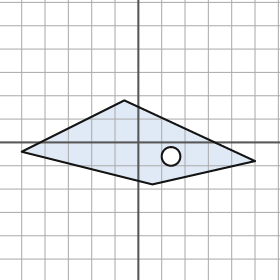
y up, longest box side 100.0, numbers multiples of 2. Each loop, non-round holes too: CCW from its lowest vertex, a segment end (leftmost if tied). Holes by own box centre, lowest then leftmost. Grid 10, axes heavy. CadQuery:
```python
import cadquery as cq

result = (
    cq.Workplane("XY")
    .moveTo(6.0, -18.0)
    .lineTo(50.0, -8.0)
    .lineTo(-6.0, 18.0)
    .lineTo(-50.0, -4.0)
    .close()
    .moveTo(14.0, -6.0)
    .circle(4.0)
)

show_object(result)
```